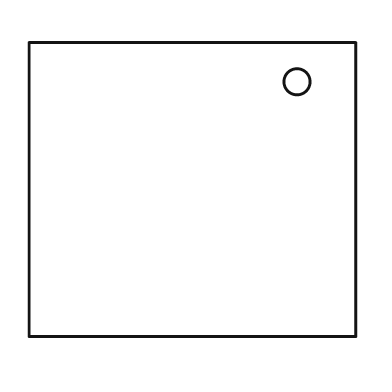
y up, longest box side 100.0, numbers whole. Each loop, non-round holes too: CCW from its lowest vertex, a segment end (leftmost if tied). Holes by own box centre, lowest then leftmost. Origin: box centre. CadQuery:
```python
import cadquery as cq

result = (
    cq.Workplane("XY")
    .moveTo(-50.0, -45.0)
    .lineTo(50.0, -45.0)
    .lineTo(50.0, 45.0)
    .lineTo(-50.0, 45.0)
    .close()
    .moveTo(32.0, 33.0)
    .circle(4.0)
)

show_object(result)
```